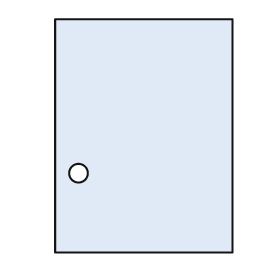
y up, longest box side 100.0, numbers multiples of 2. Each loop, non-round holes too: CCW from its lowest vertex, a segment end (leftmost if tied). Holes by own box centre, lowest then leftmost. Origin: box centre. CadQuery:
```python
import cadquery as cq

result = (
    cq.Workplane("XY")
    .moveTo(-38.0, -50.0)
    .lineTo(38.0, -50.0)
    .lineTo(38.0, 50.0)
    .lineTo(-38.0, 50.0)
    .close()
    .moveTo(-28.0, -16.0)
    .circle(4.0)
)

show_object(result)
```